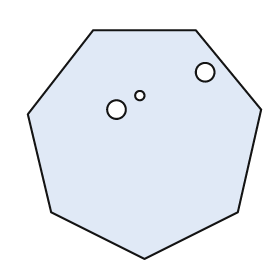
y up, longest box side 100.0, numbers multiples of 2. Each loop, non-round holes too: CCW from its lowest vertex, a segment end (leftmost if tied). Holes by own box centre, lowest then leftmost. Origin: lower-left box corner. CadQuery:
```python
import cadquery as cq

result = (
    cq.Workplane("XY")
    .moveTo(50.0, 0.0)
    .lineTo(90.0, 20.0)
    .lineTo(100.0, 64.0)
    .lineTo(72.0, 98.0)
    .lineTo(28.0, 98.0)
    .lineTo(0.0, 62.0)
    .lineTo(10.0, 20.0)
    .close()
    .moveTo(38.0, 64.0)
    .circle(4.0)
    .moveTo(48.0, 70.0)
    .circle(2.0)
    .moveTo(76.0, 80.0)
    .circle(4.0)
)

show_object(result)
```